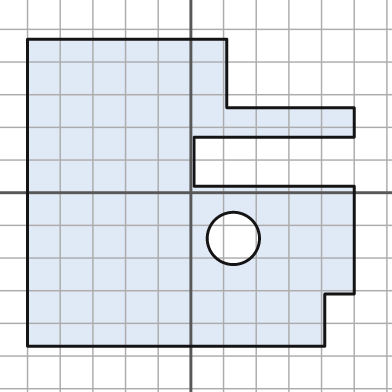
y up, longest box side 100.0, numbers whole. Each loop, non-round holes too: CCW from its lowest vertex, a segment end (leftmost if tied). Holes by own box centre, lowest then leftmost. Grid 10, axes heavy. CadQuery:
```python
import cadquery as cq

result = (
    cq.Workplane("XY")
    .moveTo(-50.0, -47.0)
    .lineTo(41.0, -47.0)
    .lineTo(41.0, -31.0)
    .lineTo(50.0, -31.0)
    .lineTo(50.0, 2.0)
    .lineTo(1.0, 2.0)
    .lineTo(1.0, 17.0)
    .lineTo(50.0, 17.0)
    .lineTo(50.0, 26.0)
    .lineTo(11.0, 26.0)
    .lineTo(11.0, 47.0)
    .lineTo(-50.0, 47.0)
    .close()
    .moveTo(13.0, -14.0)
    .circle(8.0)
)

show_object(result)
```